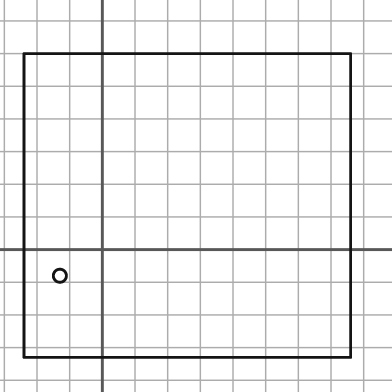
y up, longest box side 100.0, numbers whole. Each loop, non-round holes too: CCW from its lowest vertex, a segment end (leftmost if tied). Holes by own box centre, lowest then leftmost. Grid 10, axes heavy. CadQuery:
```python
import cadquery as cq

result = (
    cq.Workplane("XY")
    .moveTo(-24.0, -33.0)
    .lineTo(76.0, -33.0)
    .lineTo(76.0, 60.0)
    .lineTo(-24.0, 60.0)
    .close()
    .moveTo(-13.0, -8.0)
    .circle(2.0)
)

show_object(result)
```